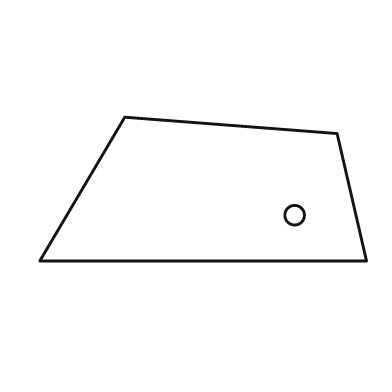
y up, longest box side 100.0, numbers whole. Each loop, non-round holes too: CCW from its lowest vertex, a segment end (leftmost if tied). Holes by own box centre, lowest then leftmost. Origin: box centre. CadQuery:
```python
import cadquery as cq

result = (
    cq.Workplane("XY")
    .moveTo(-50.0, -22.0)
    .lineTo(50.0, -22.0)
    .lineTo(41.0, 17.0)
    .lineTo(-24.0, 22.0)
    .close()
    .moveTo(28.0, -8.0)
    .circle(3.0)
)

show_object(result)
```